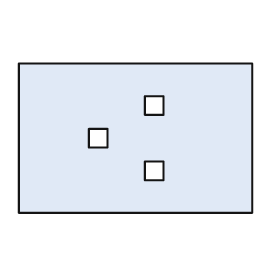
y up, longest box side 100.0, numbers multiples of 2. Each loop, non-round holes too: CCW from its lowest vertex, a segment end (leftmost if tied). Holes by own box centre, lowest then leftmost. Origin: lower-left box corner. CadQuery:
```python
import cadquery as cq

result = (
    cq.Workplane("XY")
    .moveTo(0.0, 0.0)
    .lineTo(100.0, 0.0)
    .lineTo(100.0, 64.0)
    .lineTo(0.0, 64.0)
    .close()
    .moveTo(54.0, 14.0)
    .lineTo(62.0, 14.0)
    .lineTo(62.0, 22.0)
    .lineTo(54.0, 22.0)
    .close()
    .moveTo(30.0, 28.0)
    .lineTo(38.0, 28.0)
    .lineTo(38.0, 36.0)
    .lineTo(30.0, 36.0)
    .close()
    .moveTo(54.0, 42.0)
    .lineTo(62.0, 42.0)
    .lineTo(62.0, 50.0)
    .lineTo(54.0, 50.0)
    .close()
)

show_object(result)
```